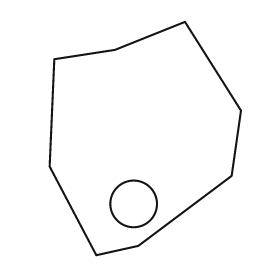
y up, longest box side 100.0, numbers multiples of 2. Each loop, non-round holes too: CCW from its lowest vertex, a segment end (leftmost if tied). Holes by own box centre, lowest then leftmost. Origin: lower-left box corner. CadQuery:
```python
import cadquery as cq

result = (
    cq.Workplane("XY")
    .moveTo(20.0, 0.0)
    .lineTo(38.0, 4.0)
    .lineTo(78.0, 34.0)
    .lineTo(82.0, 62.0)
    .lineTo(58.0, 100.0)
    .lineTo(28.0, 88.0)
    .lineTo(2.0, 84.0)
    .lineTo(0.0, 38.0)
    .close()
    .moveTo(36.0, 22.0)
    .circle(10.0)
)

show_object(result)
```